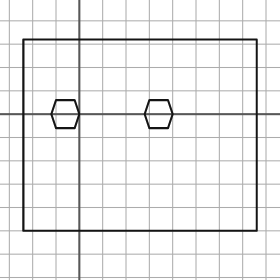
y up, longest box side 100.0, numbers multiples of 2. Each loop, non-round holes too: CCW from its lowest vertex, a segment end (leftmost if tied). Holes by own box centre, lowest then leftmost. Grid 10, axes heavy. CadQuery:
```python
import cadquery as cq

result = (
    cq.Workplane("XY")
    .moveTo(-24.0, -50.0)
    .lineTo(76.0, -50.0)
    .lineTo(76.0, 32.0)
    .lineTo(-24.0, 32.0)
    .close()
    .moveTo(-10.0, -6.0)
    .lineTo(-2.0, -6.0)
    .lineTo(0.0, 0.0)
    .lineTo(-2.0, 6.0)
    .lineTo(-10.0, 6.0)
    .lineTo(-12.0, 0.0)
    .close()
    .moveTo(30.0, -6.0)
    .lineTo(38.0, -6.0)
    .lineTo(40.0, 0.0)
    .lineTo(38.0, 6.0)
    .lineTo(30.0, 6.0)
    .lineTo(28.0, 0.0)
    .close()
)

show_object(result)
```